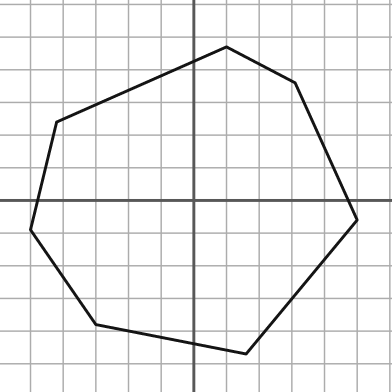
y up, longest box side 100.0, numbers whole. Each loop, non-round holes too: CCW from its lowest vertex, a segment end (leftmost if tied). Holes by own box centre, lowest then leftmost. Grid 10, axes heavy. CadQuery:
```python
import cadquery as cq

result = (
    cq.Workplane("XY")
    .moveTo(16.0, -47.0)
    .lineTo(50.0, -6.0)
    .lineTo(31.0, 36.0)
    .lineTo(10.0, 47.0)
    .lineTo(-42.0, 24.0)
    .lineTo(-50.0, -9.0)
    .lineTo(-30.0, -38.0)
    .close()
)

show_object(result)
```